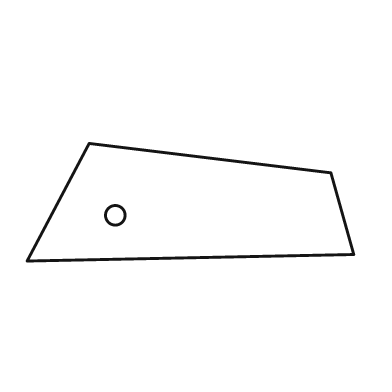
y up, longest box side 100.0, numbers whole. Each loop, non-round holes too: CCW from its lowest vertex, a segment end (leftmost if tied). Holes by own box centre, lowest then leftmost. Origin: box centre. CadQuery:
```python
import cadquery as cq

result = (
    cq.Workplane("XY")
    .moveTo(-50.0, -18.0)
    .lineTo(50.0, -16.0)
    .lineTo(43.0, 9.0)
    .lineTo(-31.0, 18.0)
    .close()
    .moveTo(-23.0, -4.0)
    .circle(3.0)
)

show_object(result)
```